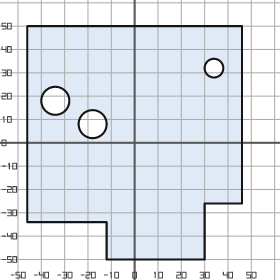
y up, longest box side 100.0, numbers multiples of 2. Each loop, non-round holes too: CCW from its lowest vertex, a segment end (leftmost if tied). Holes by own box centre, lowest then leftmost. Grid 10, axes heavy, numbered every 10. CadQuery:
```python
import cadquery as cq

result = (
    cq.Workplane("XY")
    .moveTo(-12.0, -50.0)
    .lineTo(30.0, -50.0)
    .lineTo(30.0, -26.0)
    .lineTo(46.0, -26.0)
    .lineTo(46.0, 50.0)
    .lineTo(-46.0, 50.0)
    .lineTo(-46.0, -34.0)
    .lineTo(-12.0, -34.0)
    .close()
    .moveTo(-18.0, 8.0)
    .circle(6.0)
    .moveTo(-34.0, 18.0)
    .circle(6.0)
    .moveTo(34.0, 32.0)
    .circle(4.0)
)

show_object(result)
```